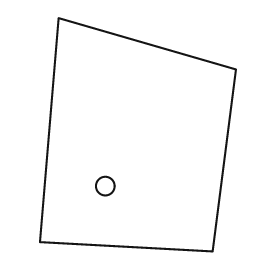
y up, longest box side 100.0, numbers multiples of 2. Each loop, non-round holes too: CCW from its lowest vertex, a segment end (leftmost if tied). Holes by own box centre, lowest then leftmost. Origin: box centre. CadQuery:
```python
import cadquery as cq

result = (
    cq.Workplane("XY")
    .moveTo(32.0, -50.0)
    .lineTo(42.0, 28.0)
    .lineTo(-34.0, 50.0)
    .lineTo(-42.0, -46.0)
    .close()
    .moveTo(-14.0, -22.0)
    .circle(4.0)
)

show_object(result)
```